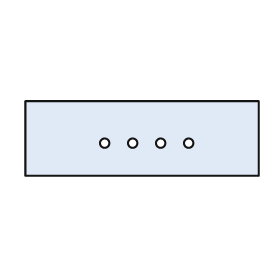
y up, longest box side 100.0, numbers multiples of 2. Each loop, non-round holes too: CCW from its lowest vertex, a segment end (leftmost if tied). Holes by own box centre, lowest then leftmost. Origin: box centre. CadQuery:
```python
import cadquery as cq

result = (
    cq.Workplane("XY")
    .moveTo(-50.0, -16.0)
    .lineTo(50.0, -16.0)
    .lineTo(50.0, 16.0)
    .lineTo(-50.0, 16.0)
    .close()
    .moveTo(-16.0, -2.0)
    .circle(2.0)
    .moveTo(-4.0, -2.0)
    .circle(2.0)
    .moveTo(8.0, -2.0)
    .circle(2.0)
    .moveTo(20.0, -2.0)
    .circle(2.0)
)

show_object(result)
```